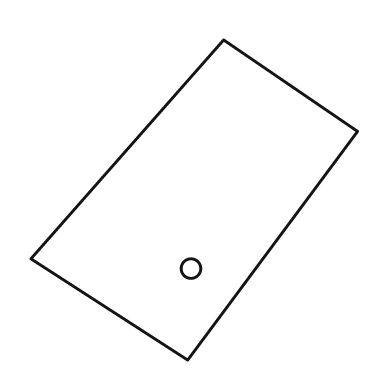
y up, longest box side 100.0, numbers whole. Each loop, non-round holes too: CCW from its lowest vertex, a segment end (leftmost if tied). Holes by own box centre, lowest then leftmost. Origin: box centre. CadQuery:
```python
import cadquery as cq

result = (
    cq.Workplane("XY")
    .moveTo(-2.0, -49.0)
    .lineTo(50.0, 21.0)
    .lineTo(9.0, 49.0)
    .lineTo(-50.0, -18.0)
    .close()
    .moveTo(-1.0, -21.0)
    .circle(3.0)
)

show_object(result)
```